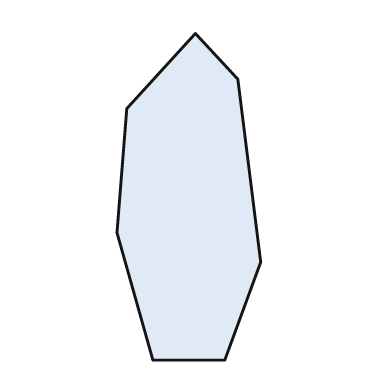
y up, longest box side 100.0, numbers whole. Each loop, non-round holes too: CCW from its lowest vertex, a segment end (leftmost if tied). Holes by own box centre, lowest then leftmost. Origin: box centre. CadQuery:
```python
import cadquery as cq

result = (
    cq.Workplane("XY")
    .moveTo(-11.0, -50.0)
    .lineTo(11.0, -50.0)
    .lineTo(22.0, -20.0)
    .lineTo(15.0, 36.0)
    .lineTo(2.0, 50.0)
    .lineTo(-19.0, 27.0)
    .lineTo(-22.0, -11.0)
    .close()
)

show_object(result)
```